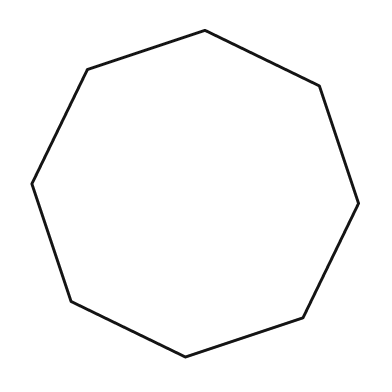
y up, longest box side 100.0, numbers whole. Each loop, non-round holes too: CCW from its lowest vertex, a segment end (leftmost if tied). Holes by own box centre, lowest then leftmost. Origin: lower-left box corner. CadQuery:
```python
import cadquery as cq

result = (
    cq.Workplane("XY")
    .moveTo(47.0, 0.0)
    .lineTo(83.0, 12.0)
    .lineTo(100.0, 47.0)
    .lineTo(88.0, 83.0)
    .lineTo(53.0, 100.0)
    .lineTo(17.0, 88.0)
    .lineTo(0.0, 53.0)
    .lineTo(12.0, 17.0)
    .close()
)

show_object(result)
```